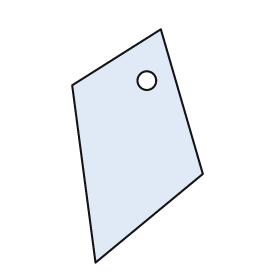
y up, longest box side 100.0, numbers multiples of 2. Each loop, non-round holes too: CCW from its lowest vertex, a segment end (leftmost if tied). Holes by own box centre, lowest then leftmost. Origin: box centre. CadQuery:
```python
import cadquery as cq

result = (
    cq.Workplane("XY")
    .moveTo(-18.0, -50.0)
    .lineTo(28.0, -12.0)
    .lineTo(10.0, 50.0)
    .lineTo(-28.0, 26.0)
    .close()
    .moveTo(4.0, 28.0)
    .circle(4.0)
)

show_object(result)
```